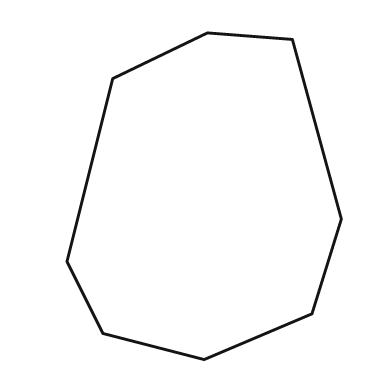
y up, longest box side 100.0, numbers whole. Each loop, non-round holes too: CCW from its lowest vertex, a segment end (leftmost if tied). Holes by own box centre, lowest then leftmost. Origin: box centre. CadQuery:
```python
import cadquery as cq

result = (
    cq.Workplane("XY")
    .moveTo(0.0, -50.0)
    .lineTo(33.0, -36.0)
    .lineTo(42.0, -7.0)
    .lineTo(27.0, 48.0)
    .lineTo(1.0, 50.0)
    .lineTo(-28.0, 36.0)
    .lineTo(-42.0, -20.0)
    .lineTo(-31.0, -42.0)
    .close()
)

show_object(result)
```